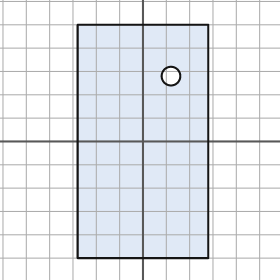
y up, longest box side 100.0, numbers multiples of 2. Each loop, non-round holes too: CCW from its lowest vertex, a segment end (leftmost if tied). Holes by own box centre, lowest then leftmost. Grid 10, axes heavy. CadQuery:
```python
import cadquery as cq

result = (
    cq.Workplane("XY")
    .moveTo(-28.0, -50.0)
    .lineTo(28.0, -50.0)
    .lineTo(28.0, 50.0)
    .lineTo(-28.0, 50.0)
    .close()
    .moveTo(12.0, 28.0)
    .circle(4.0)
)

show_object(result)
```